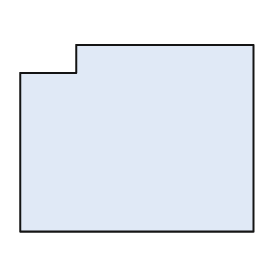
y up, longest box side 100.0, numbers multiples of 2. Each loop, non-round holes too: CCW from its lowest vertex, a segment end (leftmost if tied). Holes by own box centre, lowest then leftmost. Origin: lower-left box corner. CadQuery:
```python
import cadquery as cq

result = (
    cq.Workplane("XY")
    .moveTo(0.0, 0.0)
    .lineTo(100.0, 0.0)
    .lineTo(100.0, 80.0)
    .lineTo(24.0, 80.0)
    .lineTo(24.0, 68.0)
    .lineTo(0.0, 68.0)
    .close()
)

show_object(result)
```